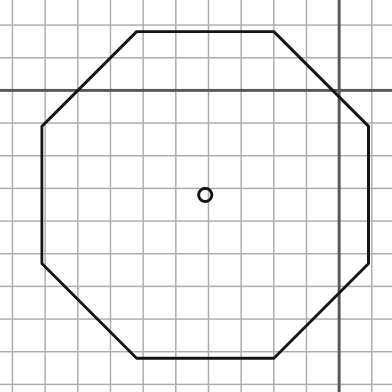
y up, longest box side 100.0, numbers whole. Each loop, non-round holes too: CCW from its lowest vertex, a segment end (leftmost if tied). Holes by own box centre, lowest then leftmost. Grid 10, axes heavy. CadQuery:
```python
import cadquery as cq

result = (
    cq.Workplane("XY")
    .moveTo(-62.0, -82.0)
    .lineTo(-20.0, -82.0)
    .lineTo(9.0, -53.0)
    .lineTo(9.0, -11.0)
    .lineTo(-20.0, 18.0)
    .lineTo(-62.0, 18.0)
    .lineTo(-91.0, -11.0)
    .lineTo(-91.0, -53.0)
    .close()
    .moveTo(-41.0, -32.0)
    .circle(2.0)
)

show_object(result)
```